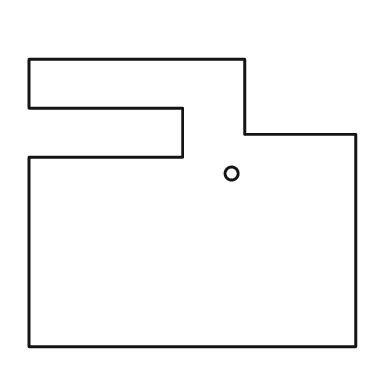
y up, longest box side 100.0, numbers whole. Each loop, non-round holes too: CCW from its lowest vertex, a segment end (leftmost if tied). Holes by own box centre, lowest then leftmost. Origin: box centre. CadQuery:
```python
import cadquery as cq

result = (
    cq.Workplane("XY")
    .moveTo(-50.0, -44.0)
    .lineTo(50.0, -44.0)
    .lineTo(50.0, 21.0)
    .lineTo(16.0, 21.0)
    .lineTo(16.0, 44.0)
    .lineTo(-50.0, 44.0)
    .lineTo(-50.0, 29.0)
    .lineTo(-3.0, 29.0)
    .lineTo(-3.0, 14.0)
    .lineTo(-50.0, 14.0)
    .close()
    .moveTo(12.0, 9.0)
    .circle(2.0)
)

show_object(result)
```